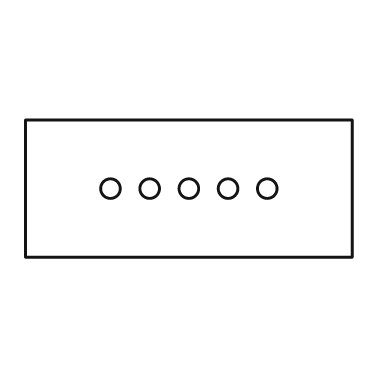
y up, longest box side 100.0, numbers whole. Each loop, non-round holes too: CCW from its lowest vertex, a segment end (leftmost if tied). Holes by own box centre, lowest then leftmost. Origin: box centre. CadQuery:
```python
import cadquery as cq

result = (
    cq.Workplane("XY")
    .moveTo(-50.0, -21.0)
    .lineTo(50.0, -21.0)
    .lineTo(50.0, 21.0)
    .lineTo(-50.0, 21.0)
    .close()
    .moveTo(-24.0, 0.0)
    .circle(3.0)
    .moveTo(-12.0, 0.0)
    .circle(3.0)
    .moveTo(0.0, 0.0)
    .circle(3.0)
    .moveTo(12.0, 0.0)
    .circle(3.0)
    .moveTo(24.0, 0.0)
    .circle(3.0)
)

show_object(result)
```